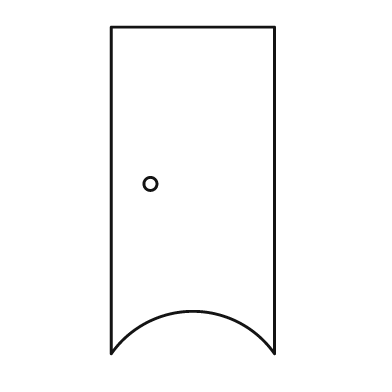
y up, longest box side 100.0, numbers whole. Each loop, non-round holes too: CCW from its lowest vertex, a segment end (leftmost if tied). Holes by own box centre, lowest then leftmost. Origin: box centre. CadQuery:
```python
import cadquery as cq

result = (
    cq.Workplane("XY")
    .moveTo(-25.0, -50.0)
    .threePointArc((0.0, -37.0), (25.0, -50.0))
    .lineTo(25.0, 50.0)
    .lineTo(-25.0, 50.0)
    .close()
    .moveTo(-13.0, 2.0)
    .circle(2.0)
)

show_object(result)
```